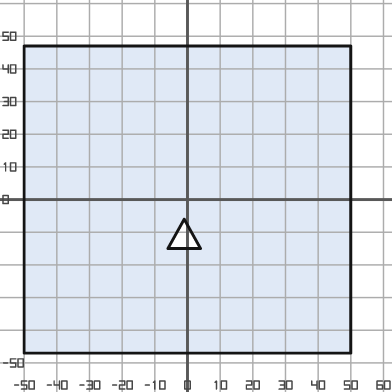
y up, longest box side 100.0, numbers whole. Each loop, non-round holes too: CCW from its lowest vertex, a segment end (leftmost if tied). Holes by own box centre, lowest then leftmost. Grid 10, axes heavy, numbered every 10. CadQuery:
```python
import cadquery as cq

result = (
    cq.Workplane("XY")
    .moveTo(-50.0, -47.0)
    .lineTo(50.0, -47.0)
    .lineTo(50.0, 47.0)
    .lineTo(-50.0, 47.0)
    .close()
    .moveTo(-6.0, -15.0)
    .lineTo(4.0, -15.0)
    .lineTo(-1.0, -6.0)
    .close()
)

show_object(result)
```